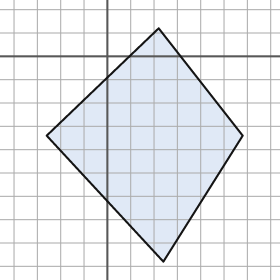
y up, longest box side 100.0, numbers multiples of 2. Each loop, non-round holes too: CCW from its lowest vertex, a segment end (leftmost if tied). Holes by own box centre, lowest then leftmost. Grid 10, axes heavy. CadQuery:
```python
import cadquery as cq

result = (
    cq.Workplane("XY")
    .moveTo(24.0, -88.0)
    .lineTo(58.0, -34.0)
    .lineTo(22.0, 12.0)
    .lineTo(-26.0, -34.0)
    .close()
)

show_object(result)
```